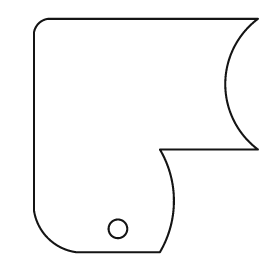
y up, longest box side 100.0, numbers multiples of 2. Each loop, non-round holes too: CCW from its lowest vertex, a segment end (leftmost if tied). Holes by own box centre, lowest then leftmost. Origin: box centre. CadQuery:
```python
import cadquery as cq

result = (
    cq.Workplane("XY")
    .moveTo(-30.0, -50.0)
    .lineTo(6.0, -50.0)
    .threePointArc((12.0, -28.0), (6.0, -6.0))
    .lineTo(48.0, -6.0)
    .threePointArc((34.0, 22.0), (48.0, 50.0))
    .lineTo(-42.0, 50.0)
    .threePointArc((-46.0, 48.0), (-48.0, 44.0))
    .lineTo(-48.0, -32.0)
    .threePointArc((-42.0, -44.0), (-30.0, -50.0))
    .close()
    .moveTo(-12.0, -40.0)
    .circle(4.0)
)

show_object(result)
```